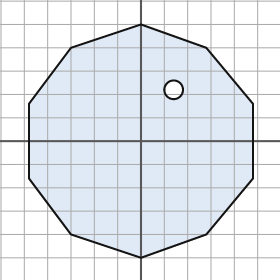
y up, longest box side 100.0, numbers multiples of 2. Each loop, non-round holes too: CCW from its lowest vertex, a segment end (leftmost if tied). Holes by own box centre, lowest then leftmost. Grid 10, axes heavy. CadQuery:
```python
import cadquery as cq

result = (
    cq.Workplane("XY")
    .moveTo(0.0, -50.0)
    .lineTo(28.0, -40.0)
    .lineTo(48.0, -16.0)
    .lineTo(48.0, 16.0)
    .lineTo(28.0, 40.0)
    .lineTo(0.0, 50.0)
    .lineTo(-30.0, 40.0)
    .lineTo(-48.0, 16.0)
    .lineTo(-48.0, -16.0)
    .lineTo(-30.0, -40.0)
    .close()
    .moveTo(14.0, 22.0)
    .circle(4.0)
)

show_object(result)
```